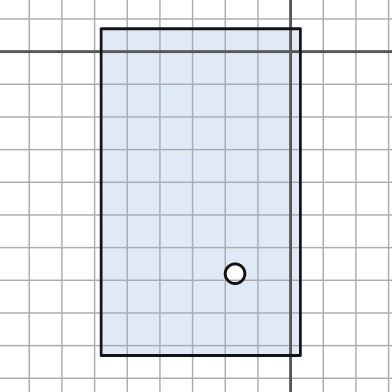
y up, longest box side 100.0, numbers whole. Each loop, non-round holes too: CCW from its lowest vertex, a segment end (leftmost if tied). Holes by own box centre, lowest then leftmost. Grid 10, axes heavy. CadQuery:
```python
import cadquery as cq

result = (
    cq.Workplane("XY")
    .moveTo(-58.0, -93.0)
    .lineTo(3.0, -93.0)
    .lineTo(3.0, 7.0)
    .lineTo(-58.0, 7.0)
    .close()
    .moveTo(-17.0, -68.0)
    .circle(3.0)
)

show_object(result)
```